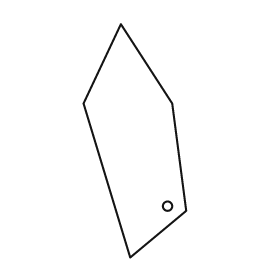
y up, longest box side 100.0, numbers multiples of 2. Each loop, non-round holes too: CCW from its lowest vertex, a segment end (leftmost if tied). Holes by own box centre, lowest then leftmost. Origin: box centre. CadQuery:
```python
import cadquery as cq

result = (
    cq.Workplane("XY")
    .moveTo(-2.0, -50.0)
    .lineTo(22.0, -30.0)
    .lineTo(16.0, 16.0)
    .lineTo(-6.0, 50.0)
    .lineTo(-22.0, 16.0)
    .close()
    .moveTo(14.0, -28.0)
    .circle(2.0)
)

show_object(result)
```